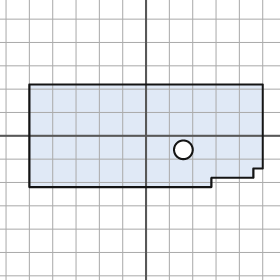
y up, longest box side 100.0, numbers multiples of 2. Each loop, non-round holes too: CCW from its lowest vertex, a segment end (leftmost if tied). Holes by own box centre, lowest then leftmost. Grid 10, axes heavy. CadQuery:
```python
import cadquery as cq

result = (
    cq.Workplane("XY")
    .moveTo(-50.0, -22.0)
    .lineTo(28.0, -22.0)
    .lineTo(28.0, -18.0)
    .lineTo(46.0, -18.0)
    .lineTo(46.0, -14.0)
    .lineTo(50.0, -14.0)
    .lineTo(50.0, 22.0)
    .lineTo(-50.0, 22.0)
    .close()
    .moveTo(16.0, -6.0)
    .circle(4.0)
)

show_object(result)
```